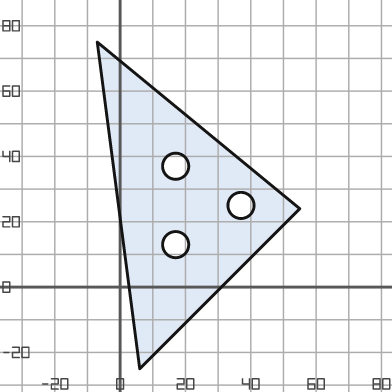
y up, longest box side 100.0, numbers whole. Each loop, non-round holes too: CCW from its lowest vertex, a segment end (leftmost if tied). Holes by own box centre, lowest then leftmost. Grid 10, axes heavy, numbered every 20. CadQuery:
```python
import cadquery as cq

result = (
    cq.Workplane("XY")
    .moveTo(6.0, -25.0)
    .lineTo(55.0, 24.0)
    .lineTo(-7.0, 75.0)
    .close()
    .moveTo(17.0, 13.0)
    .circle(4.0)
    .moveTo(37.0, 25.0)
    .circle(4.0)
    .moveTo(17.0, 37.0)
    .circle(4.0)
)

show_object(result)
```